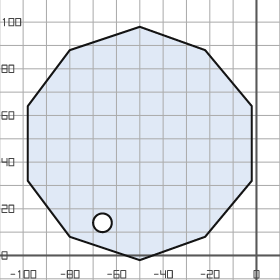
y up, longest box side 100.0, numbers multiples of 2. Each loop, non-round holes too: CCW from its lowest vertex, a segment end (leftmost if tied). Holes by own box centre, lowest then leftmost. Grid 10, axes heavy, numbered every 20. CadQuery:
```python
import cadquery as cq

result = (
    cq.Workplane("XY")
    .moveTo(-50.0, -2.0)
    .lineTo(-22.0, 8.0)
    .lineTo(-2.0, 32.0)
    .lineTo(-2.0, 64.0)
    .lineTo(-22.0, 88.0)
    .lineTo(-50.0, 98.0)
    .lineTo(-80.0, 88.0)
    .lineTo(-98.0, 64.0)
    .lineTo(-98.0, 32.0)
    .lineTo(-80.0, 8.0)
    .close()
    .moveTo(-66.0, 14.0)
    .circle(4.0)
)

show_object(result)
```